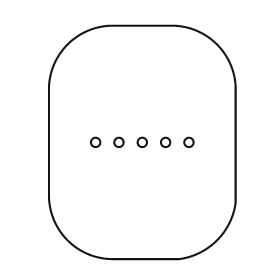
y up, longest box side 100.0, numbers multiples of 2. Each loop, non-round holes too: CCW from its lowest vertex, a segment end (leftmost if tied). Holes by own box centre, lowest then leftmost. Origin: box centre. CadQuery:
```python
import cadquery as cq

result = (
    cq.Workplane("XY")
    .moveTo(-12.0, -50.0)
    .lineTo(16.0, -50.0)
    .threePointArc((32.0, -42.0), (40.0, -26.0))
    .lineTo(40.0, 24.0)
    .threePointArc((32.0, 42.0), (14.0, 50.0))
    .lineTo(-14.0, 50.0)
    .threePointArc((-32.0, 42.0), (-40.0, 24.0))
    .lineTo(-40.0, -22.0)
    .threePointArc((-32.0, -42.0), (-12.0, -50.0))
    .close()
    .moveTo(-20.0, 0.0)
    .circle(2.0)
    .moveTo(-10.0, 0.0)
    .circle(2.0)
    .moveTo(0.0, 0.0)
    .circle(2.0)
    .moveTo(10.0, 0.0)
    .circle(2.0)
    .moveTo(20.0, 0.0)
    .circle(2.0)
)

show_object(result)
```